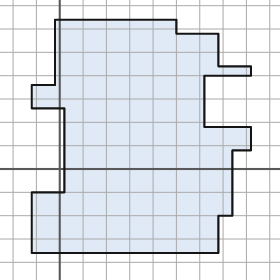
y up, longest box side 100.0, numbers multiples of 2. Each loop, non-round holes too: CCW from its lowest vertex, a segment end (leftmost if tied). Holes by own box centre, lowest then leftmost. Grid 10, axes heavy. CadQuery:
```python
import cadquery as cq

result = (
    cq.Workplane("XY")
    .moveTo(-12.0, -36.0)
    .lineTo(68.0, -36.0)
    .lineTo(68.0, -20.0)
    .lineTo(74.0, -20.0)
    .lineTo(74.0, 8.0)
    .lineTo(82.0, 8.0)
    .lineTo(82.0, 18.0)
    .lineTo(62.0, 18.0)
    .lineTo(62.0, 40.0)
    .lineTo(82.0, 40.0)
    .lineTo(82.0, 44.0)
    .lineTo(68.0, 44.0)
    .lineTo(68.0, 58.0)
    .lineTo(50.0, 58.0)
    .lineTo(50.0, 64.0)
    .lineTo(-2.0, 64.0)
    .lineTo(-2.0, 36.0)
    .lineTo(-12.0, 36.0)
    .lineTo(-12.0, 26.0)
    .lineTo(2.0, 26.0)
    .lineTo(2.0, -10.0)
    .lineTo(-12.0, -10.0)
    .close()
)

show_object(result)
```